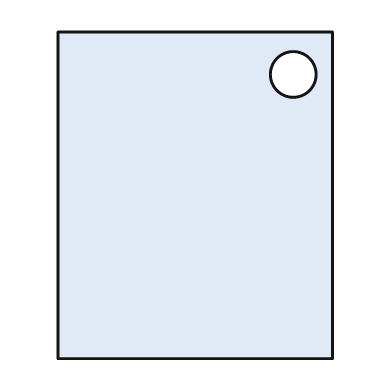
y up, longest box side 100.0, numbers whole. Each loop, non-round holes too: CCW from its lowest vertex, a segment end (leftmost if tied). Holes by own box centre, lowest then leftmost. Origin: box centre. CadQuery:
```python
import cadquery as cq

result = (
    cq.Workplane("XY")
    .moveTo(-42.0, -50.0)
    .lineTo(42.0, -50.0)
    .lineTo(42.0, 50.0)
    .lineTo(-42.0, 50.0)
    .close()
    .moveTo(30.0, 37.0)
    .circle(7.0)
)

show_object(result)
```